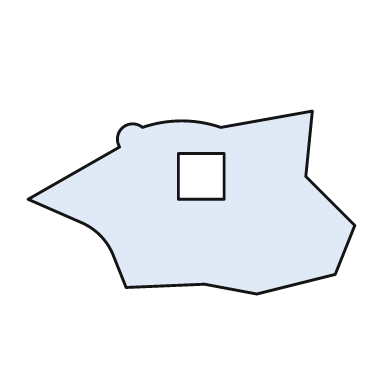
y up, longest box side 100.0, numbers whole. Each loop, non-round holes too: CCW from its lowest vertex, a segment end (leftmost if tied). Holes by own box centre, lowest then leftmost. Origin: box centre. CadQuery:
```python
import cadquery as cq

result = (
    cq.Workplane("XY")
    .moveTo(20.0, -28.0)
    .lineTo(44.0, -22.0)
    .lineTo(50.0, -7.0)
    .lineTo(35.0, 8.0)
    .lineTo(37.0, 28.0)
    .lineTo(9.0, 23.0)
    .threePointArc((-3.0, 25.0), (-15.0, 23.0))
    .threePointArc((-21.0, 23.0), (-22.0, 17.0))
    .lineTo(-50.0, 1.0)
    .lineTo(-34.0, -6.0)
    .threePointArc((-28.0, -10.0), (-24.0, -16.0))
    .lineTo(-20.0, -26.0)
    .lineTo(4.0, -25.0)
    .close()
    .moveTo(-4.0, 1.0)
    .lineTo(10.0, 1.0)
    .lineTo(10.0, 15.0)
    .lineTo(-4.0, 15.0)
    .close()
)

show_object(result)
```